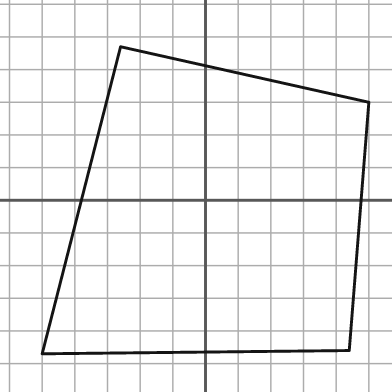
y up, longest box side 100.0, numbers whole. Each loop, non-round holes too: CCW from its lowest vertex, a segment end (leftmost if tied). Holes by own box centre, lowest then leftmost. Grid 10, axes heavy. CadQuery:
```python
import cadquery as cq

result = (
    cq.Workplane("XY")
    .moveTo(-50.0, -47.0)
    .lineTo(44.0, -46.0)
    .lineTo(50.0, 30.0)
    .lineTo(-26.0, 47.0)
    .close()
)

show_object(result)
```